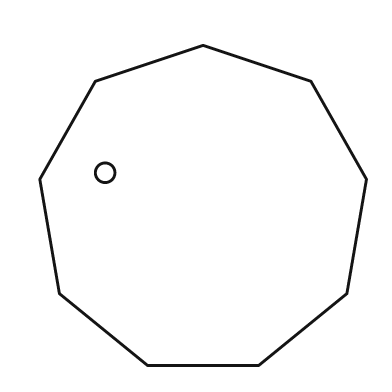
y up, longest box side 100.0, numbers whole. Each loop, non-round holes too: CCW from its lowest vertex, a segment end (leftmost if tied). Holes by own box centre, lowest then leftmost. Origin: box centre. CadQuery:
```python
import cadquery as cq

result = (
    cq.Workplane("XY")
    .moveTo(-17.0, -49.0)
    .lineTo(17.0, -49.0)
    .lineTo(44.0, -27.0)
    .lineTo(50.0, 8.0)
    .lineTo(33.0, 38.0)
    .lineTo(0.0, 49.0)
    .lineTo(-33.0, 38.0)
    .lineTo(-50.0, 8.0)
    .lineTo(-44.0, -27.0)
    .close()
    .moveTo(-30.0, 10.0)
    .circle(3.0)
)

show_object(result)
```